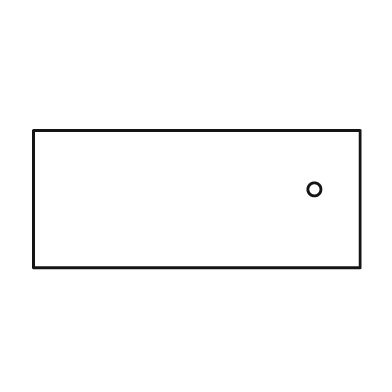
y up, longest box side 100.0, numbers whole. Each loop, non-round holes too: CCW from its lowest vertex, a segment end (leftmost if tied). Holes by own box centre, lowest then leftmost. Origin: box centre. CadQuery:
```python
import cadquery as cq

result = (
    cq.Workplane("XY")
    .moveTo(-50.0, -21.0)
    .lineTo(50.0, -21.0)
    .lineTo(50.0, 21.0)
    .lineTo(-50.0, 21.0)
    .close()
    .moveTo(36.0, 3.0)
    .circle(2.0)
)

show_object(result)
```